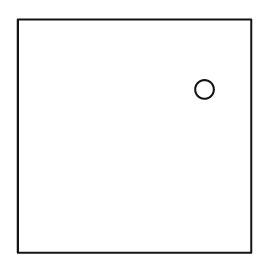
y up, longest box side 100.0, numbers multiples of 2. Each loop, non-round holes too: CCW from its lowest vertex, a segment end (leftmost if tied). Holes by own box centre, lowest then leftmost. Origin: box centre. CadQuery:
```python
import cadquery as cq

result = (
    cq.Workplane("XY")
    .moveTo(-50.0, -50.0)
    .lineTo(50.0, -50.0)
    .lineTo(50.0, 50.0)
    .lineTo(-50.0, 50.0)
    .close()
    .moveTo(30.0, 20.0)
    .circle(4.0)
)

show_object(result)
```